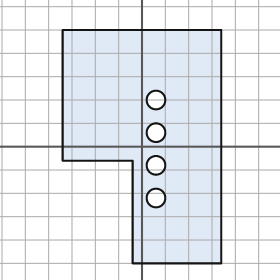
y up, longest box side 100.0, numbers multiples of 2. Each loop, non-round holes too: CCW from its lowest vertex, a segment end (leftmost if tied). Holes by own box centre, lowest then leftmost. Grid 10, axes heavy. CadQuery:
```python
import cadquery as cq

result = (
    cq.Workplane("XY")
    .moveTo(-4.0, -50.0)
    .lineTo(34.0, -50.0)
    .lineTo(34.0, 50.0)
    .lineTo(-34.0, 50.0)
    .lineTo(-34.0, -6.0)
    .lineTo(-4.0, -6.0)
    .close()
    .moveTo(6.0, -22.0)
    .circle(4.0)
    .moveTo(6.0, -8.0)
    .circle(4.0)
    .moveTo(6.0, 6.0)
    .circle(4.0)
    .moveTo(6.0, 20.0)
    .circle(4.0)
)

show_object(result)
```